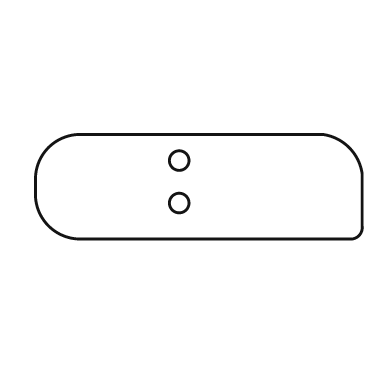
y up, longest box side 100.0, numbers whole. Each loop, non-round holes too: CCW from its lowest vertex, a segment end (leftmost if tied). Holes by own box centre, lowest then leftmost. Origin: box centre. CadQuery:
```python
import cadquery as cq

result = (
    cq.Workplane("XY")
    .moveTo(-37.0, -16.0)
    .lineTo(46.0, -16.0)
    .threePointArc((49.0, -15.0), (50.0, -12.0))
    .lineTo(50.0, 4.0)
    .threePointArc((46.0, 12.0), (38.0, 16.0))
    .lineTo(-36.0, 16.0)
    .threePointArc((-46.0, 12.0), (-50.0, 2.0))
    .lineTo(-50.0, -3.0)
    .threePointArc((-46.0, -12.0), (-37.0, -16.0))
    .close()
    .moveTo(-6.0, -5.0)
    .circle(3.0)
    .moveTo(-6.0, 8.0)
    .circle(3.0)
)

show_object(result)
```